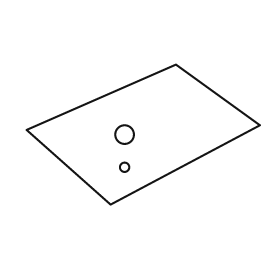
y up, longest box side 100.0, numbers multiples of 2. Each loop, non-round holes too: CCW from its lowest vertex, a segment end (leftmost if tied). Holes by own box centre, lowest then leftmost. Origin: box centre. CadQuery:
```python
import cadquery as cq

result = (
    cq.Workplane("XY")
    .moveTo(-14.0, -30.0)
    .lineTo(50.0, 4.0)
    .lineTo(14.0, 30.0)
    .lineTo(-50.0, 2.0)
    .close()
    .moveTo(-8.0, -14.0)
    .circle(2.0)
    .moveTo(-8.0, 0.0)
    .circle(4.0)
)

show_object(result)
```